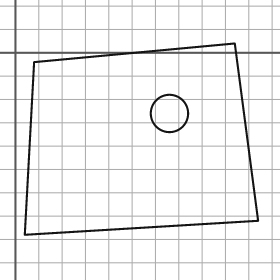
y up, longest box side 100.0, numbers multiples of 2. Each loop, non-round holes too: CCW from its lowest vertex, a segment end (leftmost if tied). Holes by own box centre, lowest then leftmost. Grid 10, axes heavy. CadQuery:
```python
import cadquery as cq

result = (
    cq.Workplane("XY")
    .moveTo(4.0, -78.0)
    .lineTo(104.0, -72.0)
    .lineTo(94.0, 4.0)
    .lineTo(8.0, -4.0)
    .close()
    .moveTo(66.0, -26.0)
    .circle(8.0)
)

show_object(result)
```